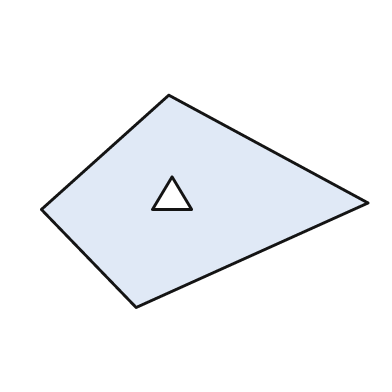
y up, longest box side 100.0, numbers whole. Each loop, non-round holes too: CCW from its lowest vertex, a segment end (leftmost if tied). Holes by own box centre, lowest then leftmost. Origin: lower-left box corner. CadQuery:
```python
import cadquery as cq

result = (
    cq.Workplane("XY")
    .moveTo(29.0, 0.0)
    .lineTo(100.0, 32.0)
    .lineTo(39.0, 65.0)
    .lineTo(0.0, 30.0)
    .close()
    .moveTo(34.0, 30.0)
    .lineTo(46.0, 30.0)
    .lineTo(40.0, 40.0)
    .close()
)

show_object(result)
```